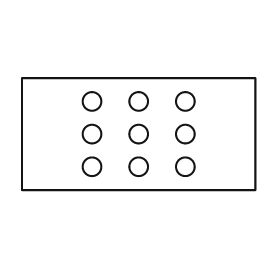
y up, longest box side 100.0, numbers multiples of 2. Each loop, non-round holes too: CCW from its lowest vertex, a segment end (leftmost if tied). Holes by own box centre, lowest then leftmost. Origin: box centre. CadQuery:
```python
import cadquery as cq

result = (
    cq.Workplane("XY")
    .moveTo(-50.0, -24.0)
    .lineTo(50.0, -24.0)
    .lineTo(50.0, 24.0)
    .lineTo(-50.0, 24.0)
    .close()
    .moveTo(-20.0, -14.0)
    .circle(4.0)
    .moveTo(0.0, -14.0)
    .circle(4.0)
    .moveTo(20.0, -14.0)
    .circle(4.0)
    .moveTo(-20.0, 0.0)
    .circle(4.0)
    .moveTo(0.0, 0.0)
    .circle(4.0)
    .moveTo(20.0, 0.0)
    .circle(4.0)
    .moveTo(-20.0, 14.0)
    .circle(4.0)
    .moveTo(0.0, 14.0)
    .circle(4.0)
    .moveTo(20.0, 14.0)
    .circle(4.0)
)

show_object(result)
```